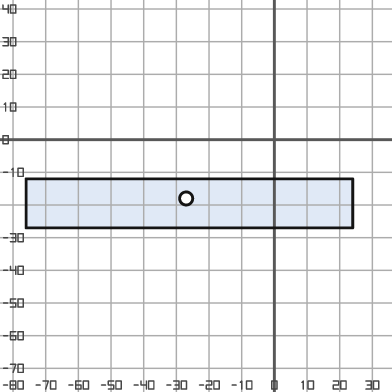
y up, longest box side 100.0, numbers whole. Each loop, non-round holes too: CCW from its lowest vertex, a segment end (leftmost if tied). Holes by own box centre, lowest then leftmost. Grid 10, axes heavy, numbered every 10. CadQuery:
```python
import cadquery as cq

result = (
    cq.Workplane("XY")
    .moveTo(-76.0, -27.0)
    .lineTo(24.0, -27.0)
    .lineTo(24.0, -12.0)
    .lineTo(-76.0, -12.0)
    .close()
    .moveTo(-27.0, -18.0)
    .circle(2.0)
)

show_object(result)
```